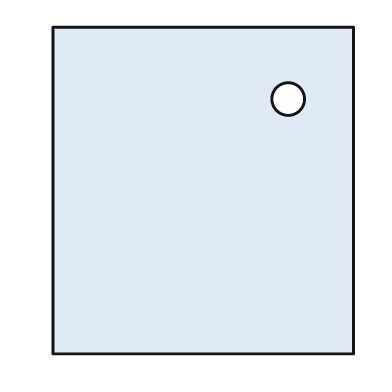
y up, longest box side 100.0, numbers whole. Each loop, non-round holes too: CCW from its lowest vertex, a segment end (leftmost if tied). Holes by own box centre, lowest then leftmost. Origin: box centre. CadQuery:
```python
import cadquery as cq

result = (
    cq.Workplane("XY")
    .moveTo(-46.0, -50.0)
    .lineTo(46.0, -50.0)
    .lineTo(46.0, 50.0)
    .lineTo(-46.0, 50.0)
    .close()
    .moveTo(26.0, 28.0)
    .circle(5.0)
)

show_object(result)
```